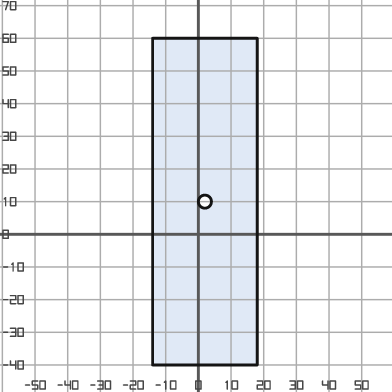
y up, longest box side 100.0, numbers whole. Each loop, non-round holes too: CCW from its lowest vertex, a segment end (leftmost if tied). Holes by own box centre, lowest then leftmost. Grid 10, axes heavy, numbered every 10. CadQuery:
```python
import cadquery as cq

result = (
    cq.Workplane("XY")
    .moveTo(-14.0, -40.0)
    .lineTo(18.0, -40.0)
    .lineTo(18.0, 60.0)
    .lineTo(-14.0, 60.0)
    .close()
    .moveTo(2.0, 10.0)
    .circle(2.0)
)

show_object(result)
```